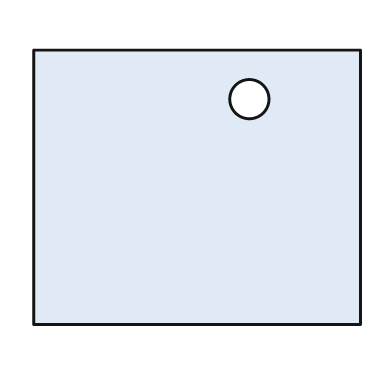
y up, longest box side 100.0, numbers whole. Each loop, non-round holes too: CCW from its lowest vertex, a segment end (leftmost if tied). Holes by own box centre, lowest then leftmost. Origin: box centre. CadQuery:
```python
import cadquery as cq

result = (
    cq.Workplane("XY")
    .moveTo(-50.0, -42.0)
    .lineTo(50.0, -42.0)
    .lineTo(50.0, 42.0)
    .lineTo(-50.0, 42.0)
    .close()
    .moveTo(16.0, 27.0)
    .circle(6.0)
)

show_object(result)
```